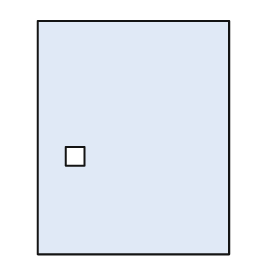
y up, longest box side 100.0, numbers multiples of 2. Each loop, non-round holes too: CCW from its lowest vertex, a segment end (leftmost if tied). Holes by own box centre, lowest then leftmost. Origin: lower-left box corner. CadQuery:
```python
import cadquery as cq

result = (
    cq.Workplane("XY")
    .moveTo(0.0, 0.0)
    .lineTo(82.0, 0.0)
    .lineTo(82.0, 100.0)
    .lineTo(0.0, 100.0)
    .close()
    .moveTo(12.0, 38.0)
    .lineTo(20.0, 38.0)
    .lineTo(20.0, 46.0)
    .lineTo(12.0, 46.0)
    .close()
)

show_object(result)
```